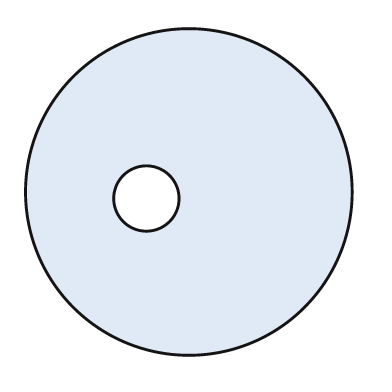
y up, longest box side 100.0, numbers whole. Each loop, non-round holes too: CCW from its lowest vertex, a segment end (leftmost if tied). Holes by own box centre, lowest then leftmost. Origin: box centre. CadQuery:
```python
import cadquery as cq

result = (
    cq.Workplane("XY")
    .moveTo(0.0, 0.0)
    .circle(50.0)
    .moveTo(-13.0, -2.0)
    .circle(10.0)
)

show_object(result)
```